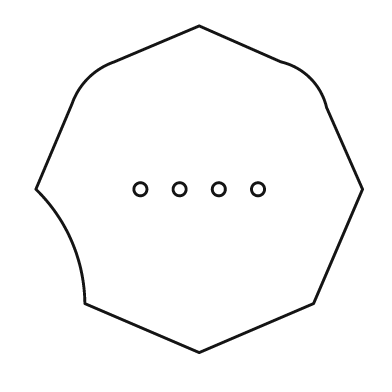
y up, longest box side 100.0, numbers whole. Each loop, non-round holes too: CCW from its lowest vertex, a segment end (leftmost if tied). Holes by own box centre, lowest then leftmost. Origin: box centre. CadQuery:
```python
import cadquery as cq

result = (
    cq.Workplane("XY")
    .moveTo(0.0, -50.0)
    .lineTo(35.0, -35.0)
    .lineTo(50.0, 0.0)
    .lineTo(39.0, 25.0)
    .threePointArc((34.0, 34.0), (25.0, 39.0))
    .lineTo(0.0, 50.0)
    .lineTo(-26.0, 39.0)
    .threePointArc((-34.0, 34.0), (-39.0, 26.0))
    .lineTo(-50.0, 0.0)
    .threePointArc((-39.0, -16.0), (-35.0, -35.0))
    .close()
    .moveTo(-18.0, 0.0)
    .circle(2.0)
    .moveTo(-6.0, 0.0)
    .circle(2.0)
    .moveTo(6.0, 0.0)
    .circle(2.0)
    .moveTo(18.0, 0.0)
    .circle(2.0)
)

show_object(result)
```